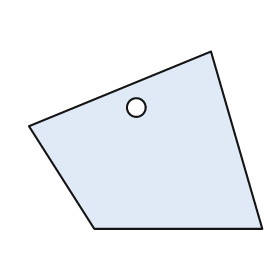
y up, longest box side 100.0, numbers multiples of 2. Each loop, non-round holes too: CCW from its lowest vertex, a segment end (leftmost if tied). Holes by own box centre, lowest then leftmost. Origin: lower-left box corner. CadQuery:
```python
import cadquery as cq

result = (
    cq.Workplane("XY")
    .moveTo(28.0, 0.0)
    .lineTo(100.0, 0.0)
    .lineTo(78.0, 76.0)
    .lineTo(0.0, 44.0)
    .close()
    .moveTo(46.0, 52.0)
    .circle(4.0)
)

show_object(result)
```